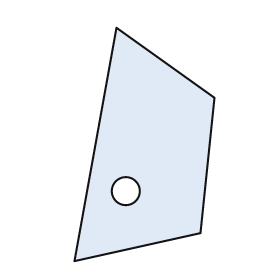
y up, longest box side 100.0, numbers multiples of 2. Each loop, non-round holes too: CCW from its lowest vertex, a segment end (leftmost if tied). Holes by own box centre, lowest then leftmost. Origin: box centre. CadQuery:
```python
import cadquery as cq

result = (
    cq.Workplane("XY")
    .moveTo(-30.0, -50.0)
    .lineTo(24.0, -38.0)
    .lineTo(30.0, 20.0)
    .lineTo(-12.0, 50.0)
    .close()
    .moveTo(-8.0, -20.0)
    .circle(6.0)
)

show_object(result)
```